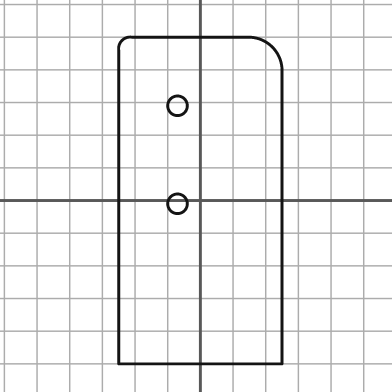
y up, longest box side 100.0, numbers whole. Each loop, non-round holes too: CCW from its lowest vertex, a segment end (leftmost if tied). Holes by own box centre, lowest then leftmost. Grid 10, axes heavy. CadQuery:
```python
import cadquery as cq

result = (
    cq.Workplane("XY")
    .moveTo(-25.0, -50.0)
    .lineTo(25.0, -50.0)
    .lineTo(25.0, 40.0)
    .threePointArc((22.0, 47.0), (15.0, 50.0))
    .lineTo(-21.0, 50.0)
    .threePointArc((-24.0, 49.0), (-25.0, 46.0))
    .close()
    .moveTo(-7.0, -1.0)
    .circle(3.0)
    .moveTo(-7.0, 29.0)
    .circle(3.0)
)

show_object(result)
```